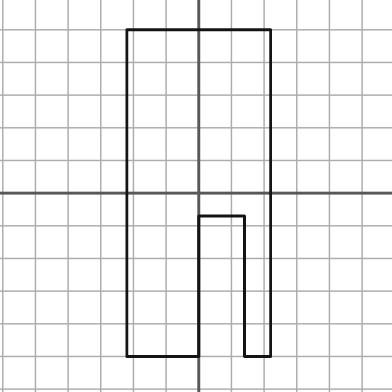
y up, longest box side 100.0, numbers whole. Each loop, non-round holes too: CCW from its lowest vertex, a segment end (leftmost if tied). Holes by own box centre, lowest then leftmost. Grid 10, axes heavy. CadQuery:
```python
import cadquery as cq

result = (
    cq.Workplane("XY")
    .moveTo(-22.0, -50.0)
    .lineTo(0.0, -50.0)
    .lineTo(0.0, -7.0)
    .lineTo(14.0, -7.0)
    .lineTo(14.0, -50.0)
    .lineTo(22.0, -50.0)
    .lineTo(22.0, 50.0)
    .lineTo(-22.0, 50.0)
    .close()
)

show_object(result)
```